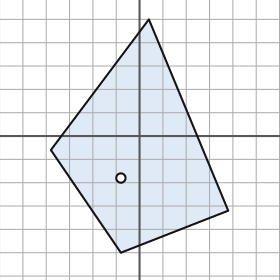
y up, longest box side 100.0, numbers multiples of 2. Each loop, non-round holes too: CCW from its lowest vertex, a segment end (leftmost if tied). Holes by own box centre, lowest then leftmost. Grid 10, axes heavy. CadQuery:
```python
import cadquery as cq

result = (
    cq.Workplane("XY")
    .moveTo(-8.0, -50.0)
    .lineTo(38.0, -32.0)
    .lineTo(4.0, 50.0)
    .lineTo(-38.0, -6.0)
    .close()
    .moveTo(-8.0, -18.0)
    .circle(2.0)
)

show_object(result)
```